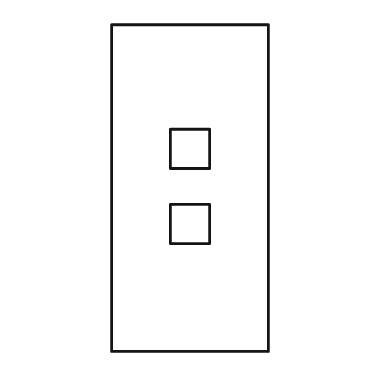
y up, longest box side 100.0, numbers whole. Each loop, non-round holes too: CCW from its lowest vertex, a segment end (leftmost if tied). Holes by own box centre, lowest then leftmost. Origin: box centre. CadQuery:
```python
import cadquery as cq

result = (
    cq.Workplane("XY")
    .moveTo(-24.0, -50.0)
    .lineTo(24.0, -50.0)
    .lineTo(24.0, 50.0)
    .lineTo(-24.0, 50.0)
    .close()
    .moveTo(-6.0, -17.0)
    .lineTo(6.0, -17.0)
    .lineTo(6.0, -5.0)
    .lineTo(-6.0, -5.0)
    .close()
    .moveTo(-6.0, 6.0)
    .lineTo(6.0, 6.0)
    .lineTo(6.0, 18.0)
    .lineTo(-6.0, 18.0)
    .close()
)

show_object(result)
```